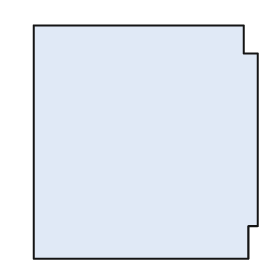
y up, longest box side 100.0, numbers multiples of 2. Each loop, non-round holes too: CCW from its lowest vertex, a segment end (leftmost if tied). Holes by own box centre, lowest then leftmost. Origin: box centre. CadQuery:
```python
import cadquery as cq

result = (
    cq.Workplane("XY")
    .moveTo(-48.0, -50.0)
    .lineTo(44.0, -50.0)
    .lineTo(44.0, -36.0)
    .lineTo(48.0, -36.0)
    .lineTo(48.0, 38.0)
    .lineTo(42.0, 38.0)
    .lineTo(42.0, 50.0)
    .lineTo(-48.0, 50.0)
    .close()
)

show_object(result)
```